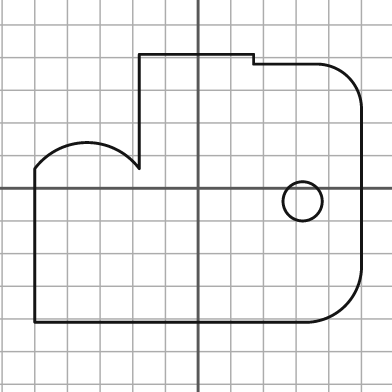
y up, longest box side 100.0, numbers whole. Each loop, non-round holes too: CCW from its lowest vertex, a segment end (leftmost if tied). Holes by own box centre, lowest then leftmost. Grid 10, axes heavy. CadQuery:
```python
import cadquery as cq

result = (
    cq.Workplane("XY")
    .moveTo(-50.0, -41.0)
    .lineTo(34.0, -41.0)
    .threePointArc((45.0, -36.0), (50.0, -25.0))
    .lineTo(50.0, 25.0)
    .threePointArc((46.0, 34.0), (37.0, 38.0))
    .lineTo(17.0, 38.0)
    .lineTo(17.0, 41.0)
    .lineTo(-18.0, 41.0)
    .lineTo(-18.0, 6.0)
    .threePointArc((-34.0, 14.0), (-50.0, 6.0))
    .close()
    .moveTo(32.0, -4.0)
    .circle(6.0)
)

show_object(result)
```